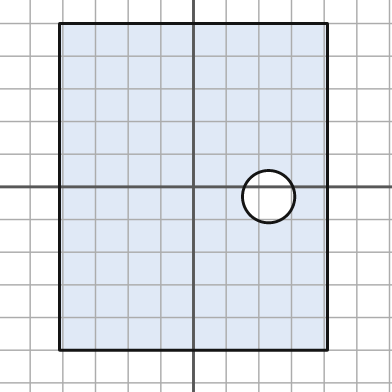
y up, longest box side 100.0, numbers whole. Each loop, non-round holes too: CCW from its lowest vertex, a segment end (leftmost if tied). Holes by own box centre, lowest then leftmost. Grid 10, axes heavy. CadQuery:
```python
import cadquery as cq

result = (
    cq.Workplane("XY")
    .moveTo(-41.0, -50.0)
    .lineTo(41.0, -50.0)
    .lineTo(41.0, 50.0)
    .lineTo(-41.0, 50.0)
    .close()
    .moveTo(23.0, -3.0)
    .circle(8.0)
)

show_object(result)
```